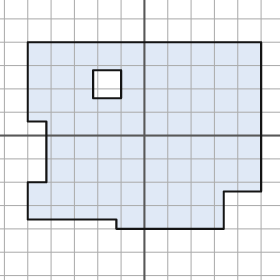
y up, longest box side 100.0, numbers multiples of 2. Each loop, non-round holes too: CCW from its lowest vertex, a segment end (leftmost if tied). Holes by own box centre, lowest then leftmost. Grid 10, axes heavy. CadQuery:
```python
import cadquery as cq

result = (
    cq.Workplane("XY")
    .moveTo(-12.0, -40.0)
    .lineTo(34.0, -40.0)
    .lineTo(34.0, -24.0)
    .lineTo(50.0, -24.0)
    .lineTo(50.0, 40.0)
    .lineTo(-50.0, 40.0)
    .lineTo(-50.0, 6.0)
    .lineTo(-42.0, 6.0)
    .lineTo(-42.0, -20.0)
    .lineTo(-50.0, -20.0)
    .lineTo(-50.0, -36.0)
    .lineTo(-12.0, -36.0)
    .close()
    .moveTo(-22.0, 16.0)
    .lineTo(-10.0, 16.0)
    .lineTo(-10.0, 28.0)
    .lineTo(-22.0, 28.0)
    .close()
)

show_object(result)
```